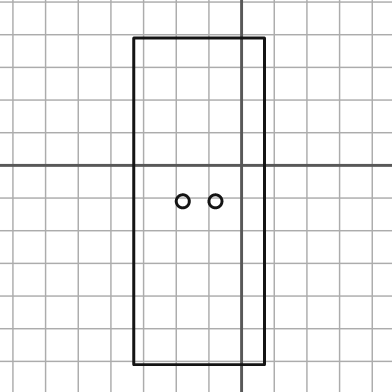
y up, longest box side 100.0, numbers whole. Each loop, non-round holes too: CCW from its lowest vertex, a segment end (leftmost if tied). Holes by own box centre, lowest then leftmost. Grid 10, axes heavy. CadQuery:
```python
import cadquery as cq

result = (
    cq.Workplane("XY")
    .moveTo(-33.0, -61.0)
    .lineTo(7.0, -61.0)
    .lineTo(7.0, 39.0)
    .lineTo(-33.0, 39.0)
    .close()
    .moveTo(-18.0, -11.0)
    .circle(2.0)
    .moveTo(-8.0, -11.0)
    .circle(2.0)
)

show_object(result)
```